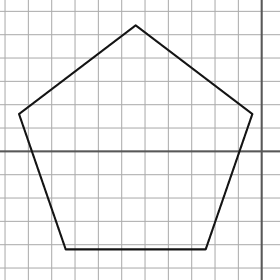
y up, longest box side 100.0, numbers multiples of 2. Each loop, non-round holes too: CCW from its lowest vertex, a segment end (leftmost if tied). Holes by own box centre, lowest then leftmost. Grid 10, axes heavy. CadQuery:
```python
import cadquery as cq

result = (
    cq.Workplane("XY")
    .moveTo(-84.0, -42.0)
    .lineTo(-24.0, -42.0)
    .lineTo(-4.0, 16.0)
    .lineTo(-54.0, 54.0)
    .lineTo(-104.0, 16.0)
    .close()
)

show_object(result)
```